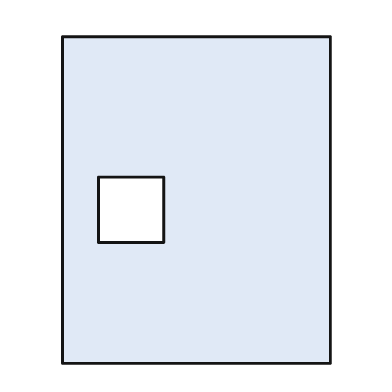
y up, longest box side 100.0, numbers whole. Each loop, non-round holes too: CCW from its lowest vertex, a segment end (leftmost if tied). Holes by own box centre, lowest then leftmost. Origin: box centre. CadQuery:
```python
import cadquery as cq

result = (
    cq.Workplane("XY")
    .moveTo(-41.0, -50.0)
    .lineTo(41.0, -50.0)
    .lineTo(41.0, 50.0)
    .lineTo(-41.0, 50.0)
    .close()
    .moveTo(-30.0, -13.0)
    .lineTo(-10.0, -13.0)
    .lineTo(-10.0, 7.0)
    .lineTo(-30.0, 7.0)
    .close()
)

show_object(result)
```